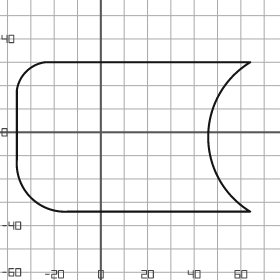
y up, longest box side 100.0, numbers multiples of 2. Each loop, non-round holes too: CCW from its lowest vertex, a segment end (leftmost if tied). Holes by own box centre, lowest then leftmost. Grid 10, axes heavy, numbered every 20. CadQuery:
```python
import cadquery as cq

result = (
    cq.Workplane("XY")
    .moveTo(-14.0, -34.0)
    .lineTo(64.0, -34.0)
    .threePointArc((46.0, -2.0), (64.0, 30.0))
    .lineTo(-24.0, 30.0)
    .threePointArc((-32.0, 26.0), (-36.0, 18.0))
    .lineTo(-36.0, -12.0)
    .threePointArc((-30.0, -28.0), (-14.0, -34.0))
    .close()
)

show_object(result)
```